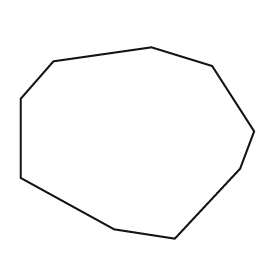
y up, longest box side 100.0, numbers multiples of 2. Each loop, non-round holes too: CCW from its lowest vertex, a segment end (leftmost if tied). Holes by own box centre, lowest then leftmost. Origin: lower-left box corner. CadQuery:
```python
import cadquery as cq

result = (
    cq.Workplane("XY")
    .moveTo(66.0, 0.0)
    .lineTo(94.0, 30.0)
    .lineTo(100.0, 46.0)
    .lineTo(82.0, 74.0)
    .lineTo(56.0, 82.0)
    .lineTo(14.0, 76.0)
    .lineTo(0.0, 60.0)
    .lineTo(0.0, 26.0)
    .lineTo(40.0, 4.0)
    .close()
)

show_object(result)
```